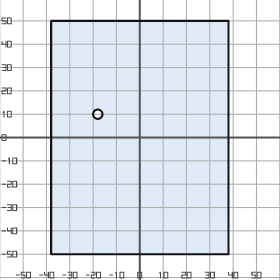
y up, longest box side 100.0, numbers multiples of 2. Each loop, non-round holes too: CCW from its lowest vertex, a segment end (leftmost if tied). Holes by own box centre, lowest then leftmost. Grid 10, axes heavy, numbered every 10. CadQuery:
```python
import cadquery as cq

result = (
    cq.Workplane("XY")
    .moveTo(-38.0, -50.0)
    .lineTo(38.0, -50.0)
    .lineTo(38.0, 50.0)
    .lineTo(-38.0, 50.0)
    .close()
    .moveTo(-18.0, 10.0)
    .circle(2.0)
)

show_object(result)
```